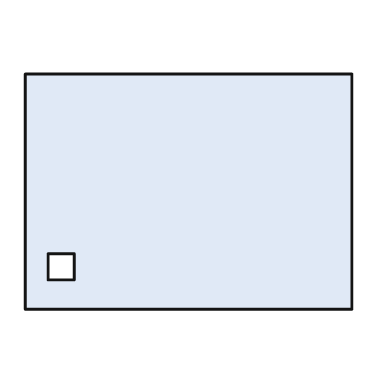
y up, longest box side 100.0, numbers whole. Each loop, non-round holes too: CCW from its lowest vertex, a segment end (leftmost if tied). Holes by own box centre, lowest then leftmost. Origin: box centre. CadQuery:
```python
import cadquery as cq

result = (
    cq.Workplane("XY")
    .moveTo(-50.0, -36.0)
    .lineTo(50.0, -36.0)
    .lineTo(50.0, 36.0)
    .lineTo(-50.0, 36.0)
    .close()
    .moveTo(-43.0, -27.0)
    .lineTo(-35.0, -27.0)
    .lineTo(-35.0, -19.0)
    .lineTo(-43.0, -19.0)
    .close()
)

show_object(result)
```